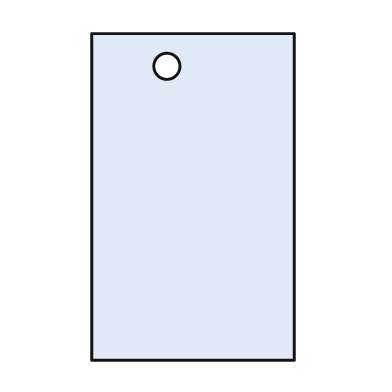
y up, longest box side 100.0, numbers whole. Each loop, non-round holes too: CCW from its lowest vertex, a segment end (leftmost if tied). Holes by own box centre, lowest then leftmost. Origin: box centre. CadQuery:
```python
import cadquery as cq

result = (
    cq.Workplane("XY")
    .moveTo(-31.0, -50.0)
    .lineTo(31.0, -50.0)
    .lineTo(31.0, 50.0)
    .lineTo(-31.0, 50.0)
    .close()
    .moveTo(-8.0, 40.0)
    .circle(4.0)
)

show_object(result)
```